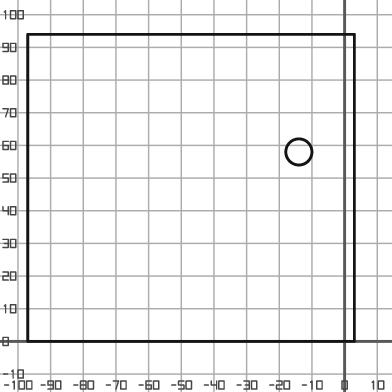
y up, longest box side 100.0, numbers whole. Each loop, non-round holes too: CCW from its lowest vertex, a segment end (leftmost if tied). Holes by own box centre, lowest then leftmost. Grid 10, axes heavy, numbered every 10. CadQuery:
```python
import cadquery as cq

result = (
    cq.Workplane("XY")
    .moveTo(-97.0, 0.0)
    .lineTo(3.0, 0.0)
    .lineTo(3.0, 94.0)
    .lineTo(-97.0, 94.0)
    .close()
    .moveTo(-14.0, 58.0)
    .circle(4.0)
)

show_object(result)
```